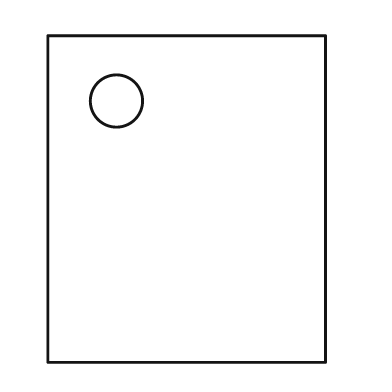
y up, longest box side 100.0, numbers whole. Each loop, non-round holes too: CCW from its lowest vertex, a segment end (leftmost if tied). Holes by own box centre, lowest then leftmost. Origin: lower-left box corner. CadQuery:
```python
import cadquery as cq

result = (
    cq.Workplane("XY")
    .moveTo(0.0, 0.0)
    .lineTo(85.0, 0.0)
    .lineTo(85.0, 100.0)
    .lineTo(0.0, 100.0)
    .close()
    .moveTo(21.0, 80.0)
    .circle(8.0)
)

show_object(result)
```